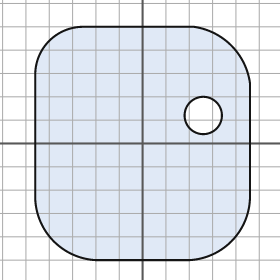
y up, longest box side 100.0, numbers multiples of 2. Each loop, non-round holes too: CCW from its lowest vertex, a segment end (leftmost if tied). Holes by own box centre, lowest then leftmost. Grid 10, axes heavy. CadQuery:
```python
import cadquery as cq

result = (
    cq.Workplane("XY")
    .moveTo(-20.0, -50.0)
    .lineTo(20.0, -50.0)
    .threePointArc((38.0, -42.0), (46.0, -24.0))
    .lineTo(46.0, 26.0)
    .threePointArc((38.0, 42.0), (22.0, 50.0))
    .lineTo(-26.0, 50.0)
    .threePointArc((-40.0, 44.0), (-46.0, 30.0))
    .lineTo(-46.0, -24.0)
    .threePointArc((-38.0, -42.0), (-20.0, -50.0))
    .close()
    .moveTo(26.0, 12.0)
    .circle(8.0)
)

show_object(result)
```